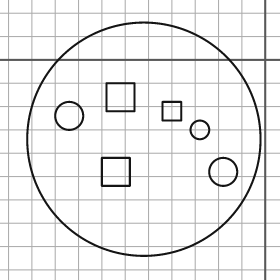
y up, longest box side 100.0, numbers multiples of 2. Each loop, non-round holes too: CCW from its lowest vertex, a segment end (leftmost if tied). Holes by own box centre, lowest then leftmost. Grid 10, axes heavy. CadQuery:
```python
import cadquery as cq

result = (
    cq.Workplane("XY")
    .moveTo(-52.0, -34.0)
    .circle(50.0)
    .moveTo(-70.0, -54.0)
    .lineTo(-58.0, -54.0)
    .lineTo(-58.0, -42.0)
    .lineTo(-70.0, -42.0)
    .close()
    .moveTo(-18.0, -48.0)
    .circle(6.0)
    .moveTo(-28.0, -30.0)
    .circle(4.0)
    .moveTo(-84.0, -24.0)
    .circle(6.0)
    .moveTo(-44.0, -26.0)
    .lineTo(-36.0, -26.0)
    .lineTo(-36.0, -18.0)
    .lineTo(-44.0, -18.0)
    .close()
    .moveTo(-68.0, -22.0)
    .lineTo(-56.0, -22.0)
    .lineTo(-56.0, -10.0)
    .lineTo(-68.0, -10.0)
    .close()
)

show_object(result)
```